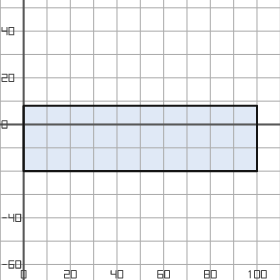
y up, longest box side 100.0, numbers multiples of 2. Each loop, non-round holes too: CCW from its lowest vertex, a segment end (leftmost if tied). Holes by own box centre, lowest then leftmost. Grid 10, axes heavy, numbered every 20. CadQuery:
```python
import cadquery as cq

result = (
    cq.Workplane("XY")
    .moveTo(0.0, -20.0)
    .lineTo(100.0, -20.0)
    .lineTo(100.0, 8.0)
    .lineTo(0.0, 8.0)
    .close()
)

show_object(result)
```